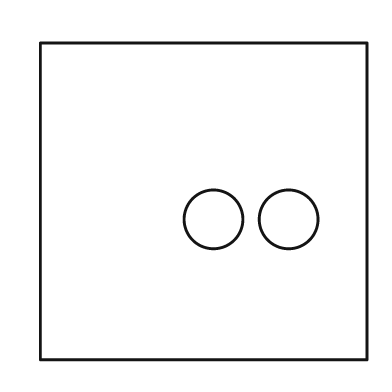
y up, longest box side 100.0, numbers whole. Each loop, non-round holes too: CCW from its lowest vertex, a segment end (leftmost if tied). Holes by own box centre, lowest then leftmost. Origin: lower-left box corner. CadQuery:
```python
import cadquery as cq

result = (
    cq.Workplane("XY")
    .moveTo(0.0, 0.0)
    .lineTo(100.0, 0.0)
    .lineTo(100.0, 97.0)
    .lineTo(0.0, 97.0)
    .close()
    .moveTo(53.0, 43.0)
    .circle(9.0)
    .moveTo(76.0, 43.0)
    .circle(9.0)
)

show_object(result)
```